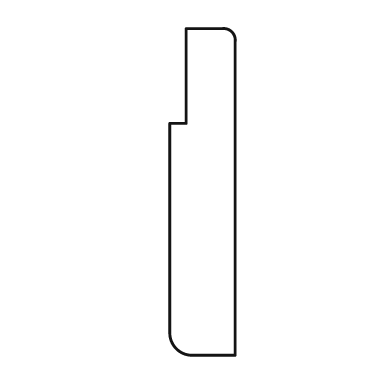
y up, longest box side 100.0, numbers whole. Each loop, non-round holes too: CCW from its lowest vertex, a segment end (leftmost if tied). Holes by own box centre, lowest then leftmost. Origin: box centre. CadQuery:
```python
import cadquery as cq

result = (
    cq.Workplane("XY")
    .moveTo(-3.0, -50.0)
    .lineTo(10.0, -50.0)
    .lineTo(10.0, 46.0)
    .threePointArc((9.0, 49.0), (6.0, 50.0))
    .lineTo(-5.0, 50.0)
    .lineTo(-5.0, 21.0)
    .lineTo(-10.0, 21.0)
    .lineTo(-10.0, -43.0)
    .threePointArc((-8.0, -48.0), (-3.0, -50.0))
    .close()
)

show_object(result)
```